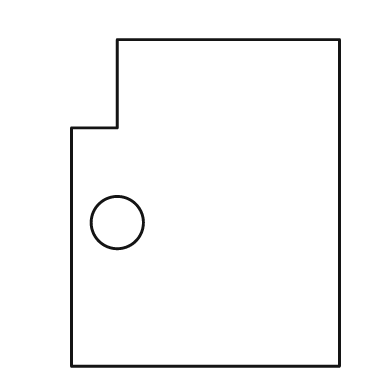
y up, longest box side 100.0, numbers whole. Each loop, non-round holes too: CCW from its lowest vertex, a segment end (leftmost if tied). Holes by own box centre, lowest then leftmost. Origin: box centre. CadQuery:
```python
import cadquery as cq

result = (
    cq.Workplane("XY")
    .moveTo(-41.0, -50.0)
    .lineTo(41.0, -50.0)
    .lineTo(41.0, 50.0)
    .lineTo(-27.0, 50.0)
    .lineTo(-27.0, 23.0)
    .lineTo(-41.0, 23.0)
    .close()
    .moveTo(-27.0, -6.0)
    .circle(8.0)
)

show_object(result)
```